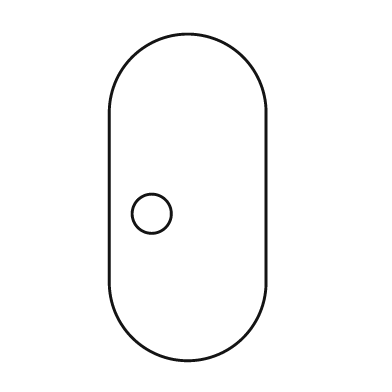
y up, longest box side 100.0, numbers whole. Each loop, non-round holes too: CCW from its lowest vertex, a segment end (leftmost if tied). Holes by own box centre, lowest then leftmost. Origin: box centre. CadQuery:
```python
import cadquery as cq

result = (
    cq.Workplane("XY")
    .moveTo(-24.0, -26.0)
    .threePointArc((0.0, -50.0), (24.0, -26.0))
    .lineTo(24.0, 26.0)
    .threePointArc((0.0, 50.0), (-24.0, 26.0))
    .close()
    .moveTo(-11.0, -5.0)
    .circle(6.0)
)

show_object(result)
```